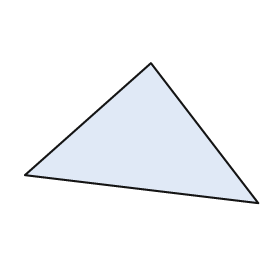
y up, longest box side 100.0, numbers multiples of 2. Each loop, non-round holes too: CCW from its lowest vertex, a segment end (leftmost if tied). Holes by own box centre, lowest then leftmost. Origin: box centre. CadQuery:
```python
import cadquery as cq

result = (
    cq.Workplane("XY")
    .moveTo(50.0, -30.0)
    .lineTo(4.0, 30.0)
    .lineTo(-50.0, -18.0)
    .close()
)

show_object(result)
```